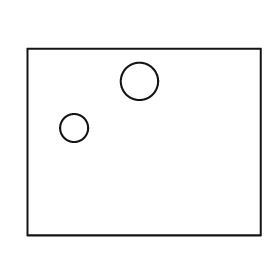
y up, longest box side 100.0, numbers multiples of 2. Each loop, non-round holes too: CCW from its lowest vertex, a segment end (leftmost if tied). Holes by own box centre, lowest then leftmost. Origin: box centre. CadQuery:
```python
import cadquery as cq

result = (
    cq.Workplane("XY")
    .moveTo(-50.0, -40.0)
    .lineTo(50.0, -40.0)
    .lineTo(50.0, 40.0)
    .lineTo(-50.0, 40.0)
    .close()
    .moveTo(-30.0, 6.0)
    .circle(6.0)
    .moveTo(-2.0, 26.0)
    .circle(8.0)
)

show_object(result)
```